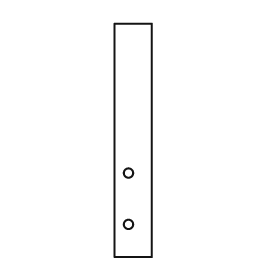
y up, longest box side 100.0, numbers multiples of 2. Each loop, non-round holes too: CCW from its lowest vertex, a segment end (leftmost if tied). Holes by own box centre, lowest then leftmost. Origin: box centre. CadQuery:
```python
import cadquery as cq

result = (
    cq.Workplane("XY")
    .moveTo(-8.0, -50.0)
    .lineTo(8.0, -50.0)
    .lineTo(8.0, 50.0)
    .lineTo(-8.0, 50.0)
    .close()
    .moveTo(-2.0, -36.0)
    .circle(2.0)
    .moveTo(-2.0, -14.0)
    .circle(2.0)
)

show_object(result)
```